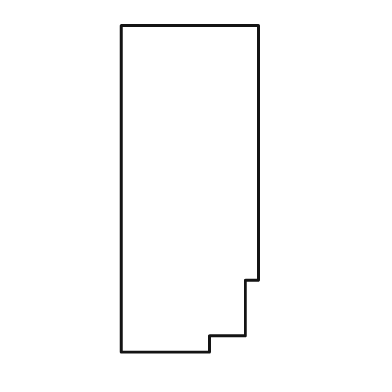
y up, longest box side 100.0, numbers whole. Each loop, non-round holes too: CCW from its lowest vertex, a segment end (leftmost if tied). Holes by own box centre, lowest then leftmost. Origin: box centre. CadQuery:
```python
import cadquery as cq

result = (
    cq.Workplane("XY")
    .moveTo(-21.0, -50.0)
    .lineTo(6.0, -50.0)
    .lineTo(6.0, -45.0)
    .lineTo(17.0, -45.0)
    .lineTo(17.0, -28.0)
    .lineTo(21.0, -28.0)
    .lineTo(21.0, 50.0)
    .lineTo(-21.0, 50.0)
    .close()
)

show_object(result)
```